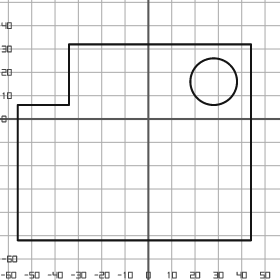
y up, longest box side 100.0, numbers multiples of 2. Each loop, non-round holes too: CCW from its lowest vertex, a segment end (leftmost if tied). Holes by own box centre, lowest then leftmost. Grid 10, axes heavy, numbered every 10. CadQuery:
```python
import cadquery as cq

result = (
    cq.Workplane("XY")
    .moveTo(-56.0, -52.0)
    .lineTo(44.0, -52.0)
    .lineTo(44.0, 32.0)
    .lineTo(-34.0, 32.0)
    .lineTo(-34.0, 6.0)
    .lineTo(-56.0, 6.0)
    .close()
    .moveTo(28.0, 16.0)
    .circle(10.0)
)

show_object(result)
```